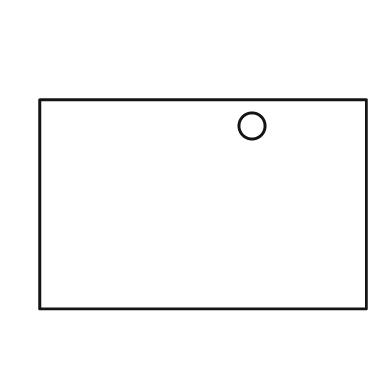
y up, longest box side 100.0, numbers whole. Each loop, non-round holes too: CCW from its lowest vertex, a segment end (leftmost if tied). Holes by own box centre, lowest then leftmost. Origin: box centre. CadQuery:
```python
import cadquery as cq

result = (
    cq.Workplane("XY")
    .moveTo(-50.0, -32.0)
    .lineTo(50.0, -32.0)
    .lineTo(50.0, 32.0)
    .lineTo(-50.0, 32.0)
    .close()
    .moveTo(15.0, 24.0)
    .circle(4.0)
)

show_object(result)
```